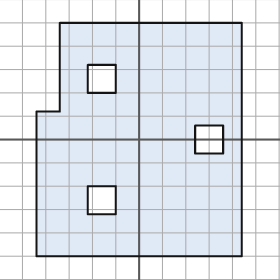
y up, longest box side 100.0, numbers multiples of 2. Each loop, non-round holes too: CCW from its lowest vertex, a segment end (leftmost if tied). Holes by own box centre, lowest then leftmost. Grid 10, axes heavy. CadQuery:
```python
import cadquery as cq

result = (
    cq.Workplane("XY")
    .moveTo(-44.0, -50.0)
    .lineTo(44.0, -50.0)
    .lineTo(44.0, 50.0)
    .lineTo(-34.0, 50.0)
    .lineTo(-34.0, 12.0)
    .lineTo(-44.0, 12.0)
    .close()
    .moveTo(-22.0, -32.0)
    .lineTo(-10.0, -32.0)
    .lineTo(-10.0, -20.0)
    .lineTo(-22.0, -20.0)
    .close()
    .moveTo(24.0, -6.0)
    .lineTo(36.0, -6.0)
    .lineTo(36.0, 6.0)
    .lineTo(24.0, 6.0)
    .close()
    .moveTo(-22.0, 20.0)
    .lineTo(-10.0, 20.0)
    .lineTo(-10.0, 32.0)
    .lineTo(-22.0, 32.0)
    .close()
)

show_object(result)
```